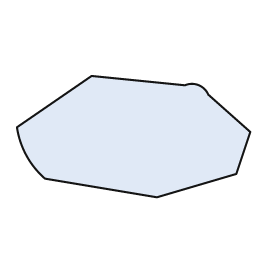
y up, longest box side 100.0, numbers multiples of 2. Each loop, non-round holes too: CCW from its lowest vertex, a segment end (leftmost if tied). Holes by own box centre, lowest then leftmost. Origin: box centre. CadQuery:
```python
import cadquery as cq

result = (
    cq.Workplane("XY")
    .moveTo(10.0, -26.0)
    .lineTo(44.0, -16.0)
    .lineTo(50.0, 2.0)
    .lineTo(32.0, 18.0)
    .threePointArc((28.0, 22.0), (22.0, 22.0))
    .lineTo(-18.0, 26.0)
    .lineTo(-50.0, 4.0)
    .threePointArc((-46.0, -8.0), (-38.0, -18.0))
    .close()
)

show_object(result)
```